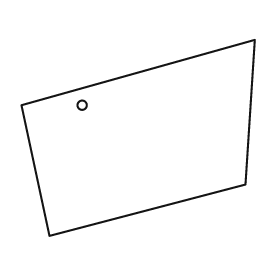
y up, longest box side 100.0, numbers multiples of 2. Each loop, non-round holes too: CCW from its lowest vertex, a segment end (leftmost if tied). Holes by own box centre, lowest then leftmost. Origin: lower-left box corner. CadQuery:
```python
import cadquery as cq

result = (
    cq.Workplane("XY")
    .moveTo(12.0, 0.0)
    .lineTo(96.0, 22.0)
    .lineTo(100.0, 84.0)
    .lineTo(0.0, 56.0)
    .close()
    .moveTo(26.0, 56.0)
    .circle(2.0)
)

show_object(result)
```